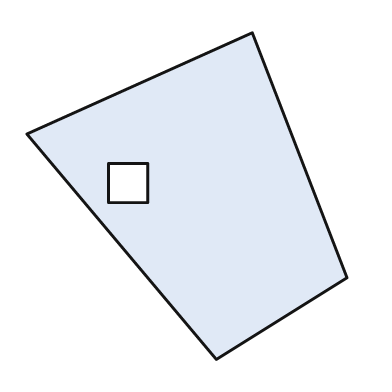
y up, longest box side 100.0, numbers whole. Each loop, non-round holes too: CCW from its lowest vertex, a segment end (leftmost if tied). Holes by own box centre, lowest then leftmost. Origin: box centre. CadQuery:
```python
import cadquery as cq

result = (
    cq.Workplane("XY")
    .moveTo(9.0, -50.0)
    .lineTo(49.0, -25.0)
    .lineTo(20.0, 50.0)
    .lineTo(-49.0, 19.0)
    .close()
    .moveTo(-24.0, -2.0)
    .lineTo(-12.0, -2.0)
    .lineTo(-12.0, 10.0)
    .lineTo(-24.0, 10.0)
    .close()
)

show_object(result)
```